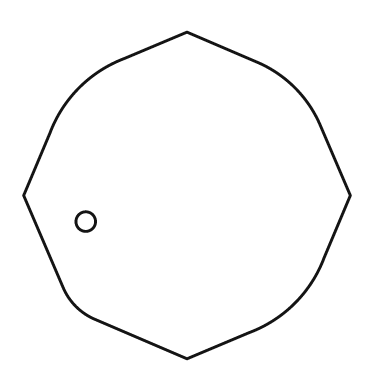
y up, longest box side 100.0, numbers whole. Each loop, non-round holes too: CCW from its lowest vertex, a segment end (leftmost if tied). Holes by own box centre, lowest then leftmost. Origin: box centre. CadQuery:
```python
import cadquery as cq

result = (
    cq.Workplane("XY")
    .moveTo(0.0, -50.0)
    .lineTo(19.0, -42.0)
    .threePointArc((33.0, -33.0), (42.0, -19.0))
    .lineTo(50.0, 0.0)
    .lineTo(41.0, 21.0)
    .threePointArc((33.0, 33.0), (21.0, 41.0))
    .lineTo(0.0, 50.0)
    .lineTo(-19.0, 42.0)
    .threePointArc((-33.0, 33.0), (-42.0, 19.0))
    .lineTo(-50.0, 0.0)
    .lineTo(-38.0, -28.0)
    .threePointArc((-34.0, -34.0), (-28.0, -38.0))
    .close()
    .moveTo(-31.0, -8.0)
    .circle(3.0)
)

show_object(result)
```